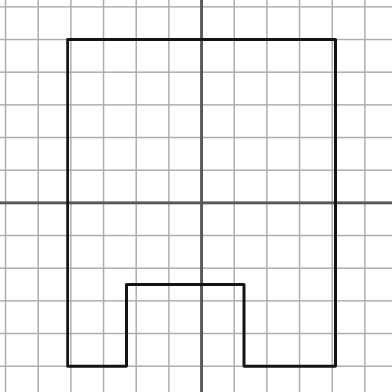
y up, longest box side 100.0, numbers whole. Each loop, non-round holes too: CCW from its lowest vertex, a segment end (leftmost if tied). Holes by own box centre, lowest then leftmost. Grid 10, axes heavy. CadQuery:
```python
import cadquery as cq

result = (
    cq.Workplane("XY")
    .moveTo(-41.0, -50.0)
    .lineTo(-23.0, -50.0)
    .lineTo(-23.0, -25.0)
    .lineTo(13.0, -25.0)
    .lineTo(13.0, -50.0)
    .lineTo(41.0, -50.0)
    .lineTo(41.0, 50.0)
    .lineTo(-41.0, 50.0)
    .close()
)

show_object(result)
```